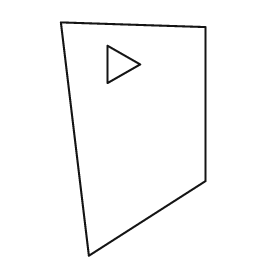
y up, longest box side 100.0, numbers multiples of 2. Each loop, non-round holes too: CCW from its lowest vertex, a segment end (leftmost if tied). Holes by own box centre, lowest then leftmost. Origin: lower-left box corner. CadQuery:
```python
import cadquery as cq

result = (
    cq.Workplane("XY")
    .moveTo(12.0, 0.0)
    .lineTo(62.0, 32.0)
    .lineTo(62.0, 98.0)
    .lineTo(0.0, 100.0)
    .close()
    .moveTo(20.0, 74.0)
    .lineTo(34.0, 82.0)
    .lineTo(20.0, 90.0)
    .close()
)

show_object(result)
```